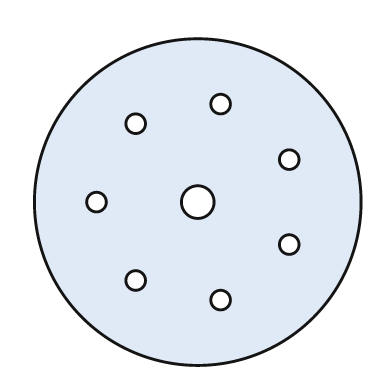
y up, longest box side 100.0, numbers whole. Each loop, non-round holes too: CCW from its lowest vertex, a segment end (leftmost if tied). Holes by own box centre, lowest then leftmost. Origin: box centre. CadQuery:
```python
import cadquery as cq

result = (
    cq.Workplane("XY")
    .moveTo(0.0, 0.0)
    .circle(50.0)
    .moveTo(7.0, -30.0)
    .circle(3.0)
    .moveTo(-19.0, -24.0)
    .circle(3.0)
    .moveTo(28.0, -13.0)
    .circle(3.0)
    .moveTo(-31.0, 0.0)
    .circle(3.0)
    .moveTo(0.0, 0.0)
    .circle(5.0)
    .moveTo(28.0, 13.0)
    .circle(3.0)
    .moveTo(-19.0, 24.0)
    .circle(3.0)
    .moveTo(7.0, 30.0)
    .circle(3.0)
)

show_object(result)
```